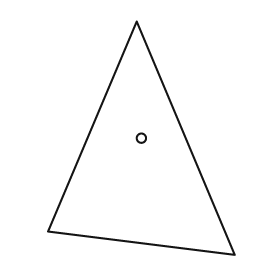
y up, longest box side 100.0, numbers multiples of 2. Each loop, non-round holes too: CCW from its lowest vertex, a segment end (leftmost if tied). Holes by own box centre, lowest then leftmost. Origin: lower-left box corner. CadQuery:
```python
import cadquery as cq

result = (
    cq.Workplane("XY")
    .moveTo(80.0, 0.0)
    .lineTo(38.0, 100.0)
    .lineTo(0.0, 10.0)
    .close()
    .moveTo(40.0, 50.0)
    .circle(2.0)
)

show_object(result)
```